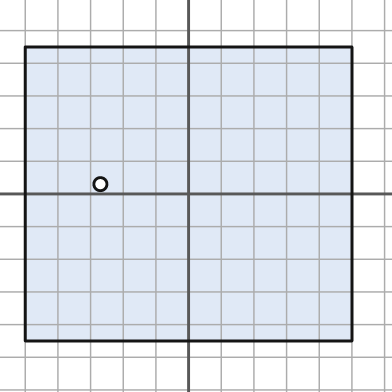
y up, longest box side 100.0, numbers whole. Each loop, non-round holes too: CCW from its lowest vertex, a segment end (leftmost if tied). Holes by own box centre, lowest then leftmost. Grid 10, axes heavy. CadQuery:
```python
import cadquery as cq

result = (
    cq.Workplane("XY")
    .moveTo(-50.0, -45.0)
    .lineTo(50.0, -45.0)
    .lineTo(50.0, 45.0)
    .lineTo(-50.0, 45.0)
    .close()
    .moveTo(-27.0, 3.0)
    .circle(2.0)
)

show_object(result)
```